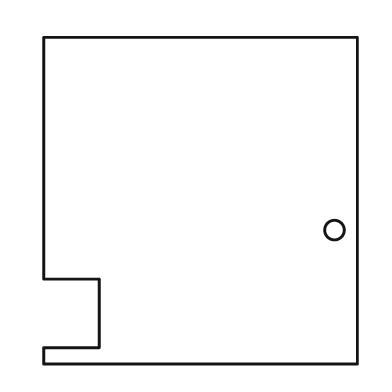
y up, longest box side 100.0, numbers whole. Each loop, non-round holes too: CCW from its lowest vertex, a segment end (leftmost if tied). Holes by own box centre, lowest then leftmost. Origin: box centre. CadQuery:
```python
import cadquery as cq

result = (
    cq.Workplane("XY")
    .moveTo(-48.0, -50.0)
    .lineTo(48.0, -50.0)
    .lineTo(48.0, 50.0)
    .lineTo(-48.0, 50.0)
    .lineTo(-48.0, -24.0)
    .lineTo(-31.0, -24.0)
    .lineTo(-31.0, -45.0)
    .lineTo(-48.0, -45.0)
    .close()
    .moveTo(41.0, -9.0)
    .circle(3.0)
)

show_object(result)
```